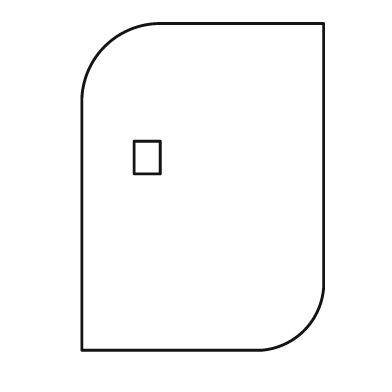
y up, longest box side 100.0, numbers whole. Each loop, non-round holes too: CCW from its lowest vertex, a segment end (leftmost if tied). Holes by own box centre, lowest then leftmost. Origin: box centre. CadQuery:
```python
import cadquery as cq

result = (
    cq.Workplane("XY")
    .moveTo(-37.0, -50.0)
    .lineTo(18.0, -50.0)
    .threePointArc((31.0, -44.0), (37.0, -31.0))
    .lineTo(37.0, 50.0)
    .lineTo(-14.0, 50.0)
    .threePointArc((-30.0, 43.0), (-37.0, 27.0))
    .close()
    .moveTo(-21.0, 4.0)
    .lineTo(-13.0, 4.0)
    .lineTo(-13.0, 14.0)
    .lineTo(-21.0, 14.0)
    .close()
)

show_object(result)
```